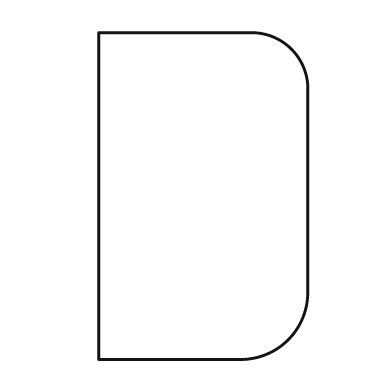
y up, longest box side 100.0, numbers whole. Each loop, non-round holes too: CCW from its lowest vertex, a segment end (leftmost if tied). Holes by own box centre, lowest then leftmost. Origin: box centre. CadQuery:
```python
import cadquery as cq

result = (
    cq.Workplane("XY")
    .moveTo(-32.0, -50.0)
    .lineTo(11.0, -50.0)
    .threePointArc((26.0, -44.0), (32.0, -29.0))
    .lineTo(32.0, 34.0)
    .threePointArc((27.0, 45.0), (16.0, 50.0))
    .lineTo(-32.0, 50.0)
    .close()
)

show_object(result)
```